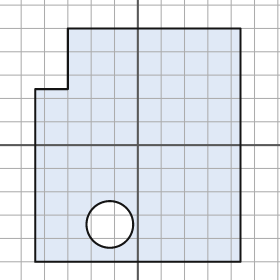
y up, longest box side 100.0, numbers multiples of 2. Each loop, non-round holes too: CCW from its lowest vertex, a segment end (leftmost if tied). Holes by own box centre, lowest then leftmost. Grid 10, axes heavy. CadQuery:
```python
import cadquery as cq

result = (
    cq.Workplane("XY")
    .moveTo(-44.0, -50.0)
    .lineTo(44.0, -50.0)
    .lineTo(44.0, 50.0)
    .lineTo(-30.0, 50.0)
    .lineTo(-30.0, 24.0)
    .lineTo(-44.0, 24.0)
    .close()
    .moveTo(-12.0, -34.0)
    .circle(10.0)
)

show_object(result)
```